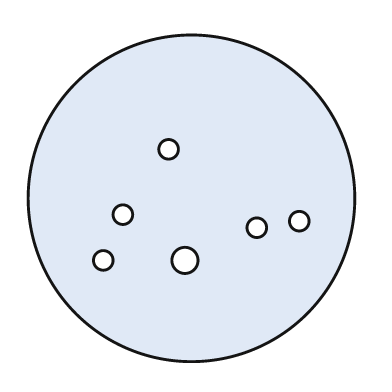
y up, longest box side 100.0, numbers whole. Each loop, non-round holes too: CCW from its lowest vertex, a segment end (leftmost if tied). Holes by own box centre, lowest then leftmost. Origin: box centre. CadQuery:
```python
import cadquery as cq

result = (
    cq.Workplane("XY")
    .moveTo(0.0, 0.0)
    .circle(50.0)
    .moveTo(-27.0, -19.0)
    .circle(3.0)
    .moveTo(-2.0, -19.0)
    .circle(4.0)
    .moveTo(20.0, -9.0)
    .circle(3.0)
    .moveTo(33.0, -7.0)
    .circle(3.0)
    .moveTo(-21.0, -5.0)
    .circle(3.0)
    .moveTo(-7.0, 15.0)
    .circle(3.0)
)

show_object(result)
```